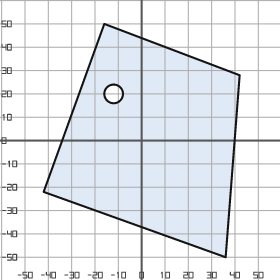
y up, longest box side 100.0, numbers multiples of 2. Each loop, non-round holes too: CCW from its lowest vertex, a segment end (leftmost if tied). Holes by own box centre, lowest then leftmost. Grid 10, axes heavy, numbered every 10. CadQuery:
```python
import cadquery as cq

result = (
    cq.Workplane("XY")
    .moveTo(36.0, -50.0)
    .lineTo(42.0, 28.0)
    .lineTo(-16.0, 50.0)
    .lineTo(-42.0, -22.0)
    .close()
    .moveTo(-12.0, 20.0)
    .circle(4.0)
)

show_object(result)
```